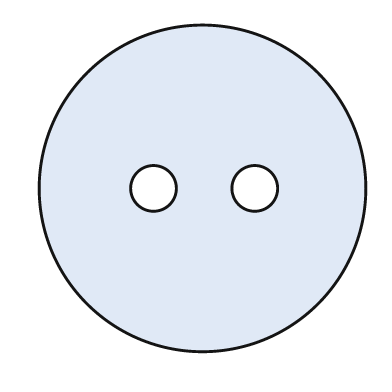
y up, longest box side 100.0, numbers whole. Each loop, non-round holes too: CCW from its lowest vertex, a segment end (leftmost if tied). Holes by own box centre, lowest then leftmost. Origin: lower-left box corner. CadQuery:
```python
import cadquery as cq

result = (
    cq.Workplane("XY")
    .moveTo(50.0, 50.0)
    .circle(50.0)
    .moveTo(35.0, 50.0)
    .circle(7.0)
    .moveTo(66.0, 50.0)
    .circle(7.0)
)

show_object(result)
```